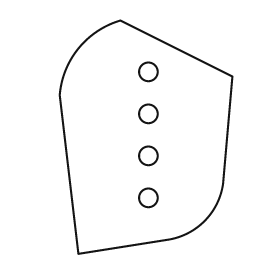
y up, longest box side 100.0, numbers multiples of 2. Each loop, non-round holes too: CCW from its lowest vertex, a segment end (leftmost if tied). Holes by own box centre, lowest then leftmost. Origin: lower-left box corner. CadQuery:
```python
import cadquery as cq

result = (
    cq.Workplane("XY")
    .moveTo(8.0, 0.0)
    .lineTo(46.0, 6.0)
    .threePointArc((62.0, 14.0), (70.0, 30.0))
    .lineTo(74.0, 76.0)
    .lineTo(26.0, 100.0)
    .threePointArc((8.0, 88.0), (0.0, 68.0))
    .close()
    .moveTo(38.0, 24.0)
    .circle(4.0)
    .moveTo(38.0, 42.0)
    .circle(4.0)
    .moveTo(38.0, 60.0)
    .circle(4.0)
    .moveTo(38.0, 78.0)
    .circle(4.0)
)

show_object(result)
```